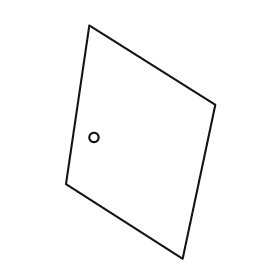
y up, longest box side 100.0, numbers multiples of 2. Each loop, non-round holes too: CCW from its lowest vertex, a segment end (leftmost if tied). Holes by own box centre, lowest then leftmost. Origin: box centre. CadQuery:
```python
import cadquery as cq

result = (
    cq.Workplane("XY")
    .moveTo(18.0, -50.0)
    .lineTo(32.0, 16.0)
    .lineTo(-22.0, 50.0)
    .lineTo(-32.0, -18.0)
    .close()
    .moveTo(-20.0, 2.0)
    .circle(2.0)
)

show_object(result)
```